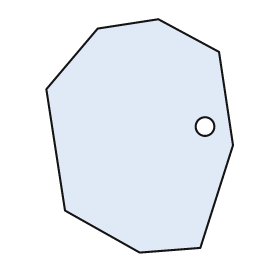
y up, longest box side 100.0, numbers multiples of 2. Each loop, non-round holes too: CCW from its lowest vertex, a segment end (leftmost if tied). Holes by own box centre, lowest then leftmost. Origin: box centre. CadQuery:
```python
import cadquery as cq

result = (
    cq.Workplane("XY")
    .moveTo(0.0, -50.0)
    .lineTo(26.0, -48.0)
    .lineTo(40.0, -4.0)
    .lineTo(34.0, 36.0)
    .lineTo(8.0, 50.0)
    .lineTo(-18.0, 46.0)
    .lineTo(-40.0, 20.0)
    .lineTo(-32.0, -32.0)
    .close()
    .moveTo(28.0, 4.0)
    .circle(4.0)
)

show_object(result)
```